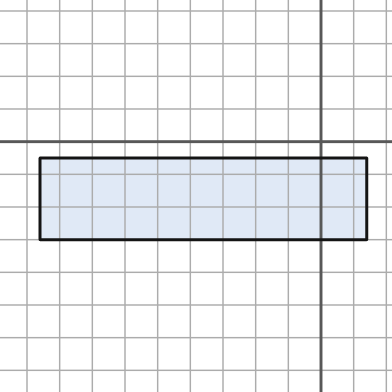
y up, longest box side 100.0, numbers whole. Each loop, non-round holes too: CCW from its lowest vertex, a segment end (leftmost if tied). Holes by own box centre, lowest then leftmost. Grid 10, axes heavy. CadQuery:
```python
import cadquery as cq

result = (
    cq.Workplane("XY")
    .moveTo(-86.0, -30.0)
    .lineTo(14.0, -30.0)
    .lineTo(14.0, -5.0)
    .lineTo(-86.0, -5.0)
    .close()
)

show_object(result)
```